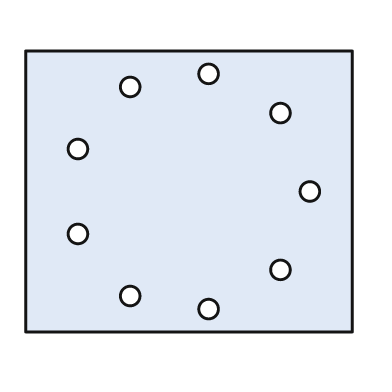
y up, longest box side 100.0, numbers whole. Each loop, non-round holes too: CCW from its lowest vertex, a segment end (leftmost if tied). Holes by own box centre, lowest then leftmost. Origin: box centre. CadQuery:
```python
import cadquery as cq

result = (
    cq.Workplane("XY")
    .moveTo(-50.0, -43.0)
    .lineTo(50.0, -43.0)
    .lineTo(50.0, 43.0)
    .lineTo(-50.0, 43.0)
    .close()
    .moveTo(6.0, -36.0)
    .circle(3.0)
    .moveTo(-18.0, -32.0)
    .circle(3.0)
    .moveTo(28.0, -24.0)
    .circle(3.0)
    .moveTo(-34.0, -13.0)
    .circle(3.0)
    .moveTo(37.0, 0.0)
    .circle(3.0)
    .moveTo(-34.0, 13.0)
    .circle(3.0)
    .moveTo(28.0, 24.0)
    .circle(3.0)
    .moveTo(-18.0, 32.0)
    .circle(3.0)
    .moveTo(6.0, 36.0)
    .circle(3.0)
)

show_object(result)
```